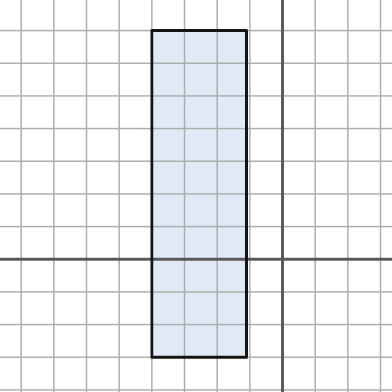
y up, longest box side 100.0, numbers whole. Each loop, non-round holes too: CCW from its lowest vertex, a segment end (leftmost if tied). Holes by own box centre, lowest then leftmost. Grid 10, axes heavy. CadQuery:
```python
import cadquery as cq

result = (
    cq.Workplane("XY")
    .moveTo(-40.0, -30.0)
    .lineTo(-11.0, -30.0)
    .lineTo(-11.0, 70.0)
    .lineTo(-40.0, 70.0)
    .close()
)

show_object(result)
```